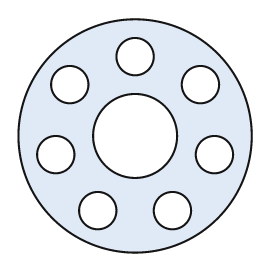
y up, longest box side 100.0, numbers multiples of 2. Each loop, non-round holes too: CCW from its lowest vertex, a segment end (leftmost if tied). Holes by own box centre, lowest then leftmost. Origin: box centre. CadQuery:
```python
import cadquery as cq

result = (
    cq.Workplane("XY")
    .moveTo(0.0, 0.0)
    .circle(50.0)
    .moveTo(-16.0, -32.0)
    .circle(8.0)
    .moveTo(16.0, -32.0)
    .circle(8.0)
    .moveTo(-34.0, -8.0)
    .circle(8.0)
    .moveTo(34.0, -8.0)
    .circle(8.0)
    .moveTo(0.0, 0.0)
    .circle(18.0)
    .moveTo(-28.0, 22.0)
    .circle(8.0)
    .moveTo(28.0, 22.0)
    .circle(8.0)
    .moveTo(0.0, 34.0)
    .circle(8.0)
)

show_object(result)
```